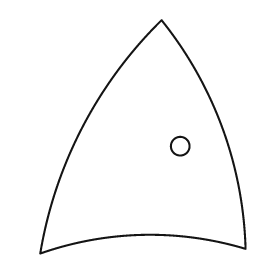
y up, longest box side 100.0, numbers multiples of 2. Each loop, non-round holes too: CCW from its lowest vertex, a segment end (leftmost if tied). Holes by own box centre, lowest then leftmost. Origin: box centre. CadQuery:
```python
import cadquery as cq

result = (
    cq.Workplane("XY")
    .moveTo(-44.0, -50.0)
    .threePointArc((0.0, -42.0), (44.0, -48.0))
    .threePointArc((34.0, 4.0), (8.0, 50.0))
    .threePointArc((-26.0, 4.0), (-44.0, -50.0))
    .close()
    .moveTo(16.0, -4.0)
    .circle(4.0)
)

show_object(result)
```